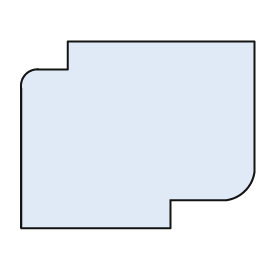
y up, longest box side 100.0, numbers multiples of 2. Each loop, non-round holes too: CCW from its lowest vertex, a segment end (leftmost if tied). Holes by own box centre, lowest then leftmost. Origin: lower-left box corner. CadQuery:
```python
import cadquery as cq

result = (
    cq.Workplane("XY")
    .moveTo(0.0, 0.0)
    .lineTo(64.0, 0.0)
    .lineTo(64.0, 12.0)
    .lineTo(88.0, 12.0)
    .threePointArc((96.0, 16.0), (100.0, 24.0))
    .lineTo(100.0, 80.0)
    .lineTo(20.0, 80.0)
    .lineTo(20.0, 68.0)
    .lineTo(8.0, 68.0)
    .threePointArc((2.0, 66.0), (0.0, 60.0))
    .close()
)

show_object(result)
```